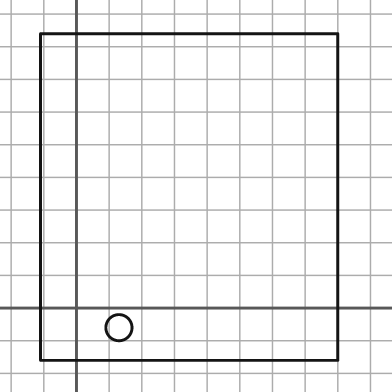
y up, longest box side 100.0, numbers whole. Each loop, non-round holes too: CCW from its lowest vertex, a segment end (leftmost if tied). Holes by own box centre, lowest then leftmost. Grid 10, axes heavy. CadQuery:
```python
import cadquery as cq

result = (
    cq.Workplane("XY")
    .moveTo(-11.0, -16.0)
    .lineTo(80.0, -16.0)
    .lineTo(80.0, 84.0)
    .lineTo(-11.0, 84.0)
    .close()
    .moveTo(13.0, -6.0)
    .circle(4.0)
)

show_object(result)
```